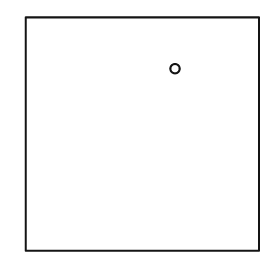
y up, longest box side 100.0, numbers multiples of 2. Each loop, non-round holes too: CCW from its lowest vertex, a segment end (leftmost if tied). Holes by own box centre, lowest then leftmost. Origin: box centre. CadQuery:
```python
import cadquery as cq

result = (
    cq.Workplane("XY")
    .moveTo(-50.0, -50.0)
    .lineTo(50.0, -50.0)
    .lineTo(50.0, 50.0)
    .lineTo(-50.0, 50.0)
    .close()
    .moveTo(14.0, 28.0)
    .circle(2.0)
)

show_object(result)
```